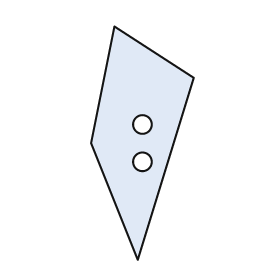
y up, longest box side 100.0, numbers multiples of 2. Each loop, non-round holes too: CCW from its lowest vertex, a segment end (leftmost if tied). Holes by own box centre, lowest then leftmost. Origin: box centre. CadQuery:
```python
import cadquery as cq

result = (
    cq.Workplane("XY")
    .moveTo(-2.0, -50.0)
    .lineTo(22.0, 28.0)
    .lineTo(-12.0, 50.0)
    .lineTo(-22.0, 0.0)
    .close()
    .moveTo(0.0, -8.0)
    .circle(4.0)
    .moveTo(0.0, 8.0)
    .circle(4.0)
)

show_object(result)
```